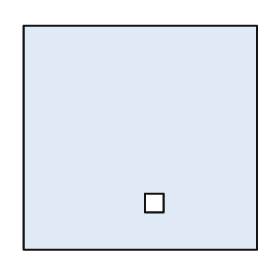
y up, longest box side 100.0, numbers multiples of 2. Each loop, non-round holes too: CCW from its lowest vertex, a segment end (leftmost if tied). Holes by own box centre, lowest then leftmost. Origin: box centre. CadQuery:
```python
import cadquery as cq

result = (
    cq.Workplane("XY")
    .moveTo(-50.0, -48.0)
    .lineTo(50.0, -48.0)
    .lineTo(50.0, 48.0)
    .lineTo(-50.0, 48.0)
    .close()
    .moveTo(2.0, -32.0)
    .lineTo(10.0, -32.0)
    .lineTo(10.0, -24.0)
    .lineTo(2.0, -24.0)
    .close()
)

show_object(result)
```